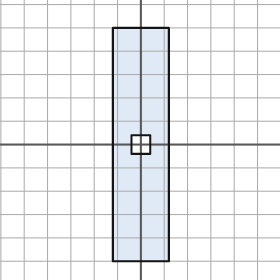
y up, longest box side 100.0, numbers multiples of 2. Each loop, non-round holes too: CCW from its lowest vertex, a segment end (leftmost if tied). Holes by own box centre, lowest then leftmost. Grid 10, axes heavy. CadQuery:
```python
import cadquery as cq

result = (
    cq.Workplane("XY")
    .moveTo(-12.0, -50.0)
    .lineTo(12.0, -50.0)
    .lineTo(12.0, 50.0)
    .lineTo(-12.0, 50.0)
    .close()
    .moveTo(-4.0, -4.0)
    .lineTo(4.0, -4.0)
    .lineTo(4.0, 4.0)
    .lineTo(-4.0, 4.0)
    .close()
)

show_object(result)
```